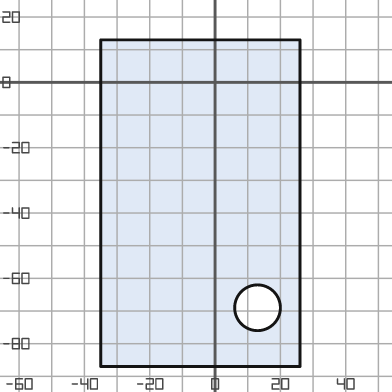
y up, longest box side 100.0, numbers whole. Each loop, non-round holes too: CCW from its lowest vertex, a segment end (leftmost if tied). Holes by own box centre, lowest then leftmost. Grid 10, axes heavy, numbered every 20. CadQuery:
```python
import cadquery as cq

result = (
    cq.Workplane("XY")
    .moveTo(-35.0, -87.0)
    .lineTo(26.0, -87.0)
    .lineTo(26.0, 13.0)
    .lineTo(-35.0, 13.0)
    .close()
    .moveTo(13.0, -69.0)
    .circle(7.0)
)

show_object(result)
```